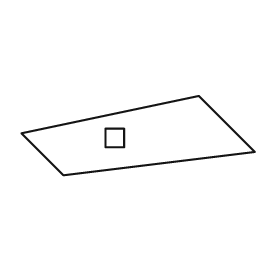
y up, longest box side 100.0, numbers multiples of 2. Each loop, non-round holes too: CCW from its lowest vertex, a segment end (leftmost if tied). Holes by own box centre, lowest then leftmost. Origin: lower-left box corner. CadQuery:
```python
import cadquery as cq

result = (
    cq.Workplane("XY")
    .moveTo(18.0, 0.0)
    .lineTo(100.0, 10.0)
    .lineTo(76.0, 34.0)
    .lineTo(0.0, 18.0)
    .close()
    .moveTo(36.0, 12.0)
    .lineTo(44.0, 12.0)
    .lineTo(44.0, 20.0)
    .lineTo(36.0, 20.0)
    .close()
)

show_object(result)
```